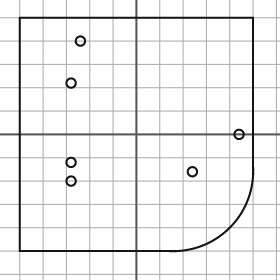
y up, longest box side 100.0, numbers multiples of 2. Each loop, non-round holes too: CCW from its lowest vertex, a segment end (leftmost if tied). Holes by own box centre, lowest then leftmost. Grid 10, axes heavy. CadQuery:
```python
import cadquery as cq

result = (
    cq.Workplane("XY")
    .moveTo(-50.0, -50.0)
    .lineTo(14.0, -50.0)
    .threePointArc((40.0, -40.0), (50.0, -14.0))
    .lineTo(50.0, 50.0)
    .lineTo(-50.0, 50.0)
    .close()
    .moveTo(-28.0, -20.0)
    .circle(2.0)
    .moveTo(24.0, -16.0)
    .circle(2.0)
    .moveTo(-28.0, -12.0)
    .circle(2.0)
    .moveTo(44.0, 0.0)
    .circle(2.0)
    .moveTo(-28.0, 22.0)
    .circle(2.0)
    .moveTo(-24.0, 40.0)
    .circle(2.0)
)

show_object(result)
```